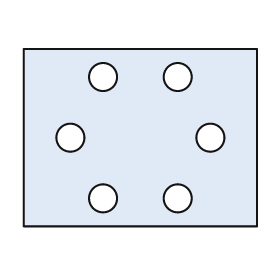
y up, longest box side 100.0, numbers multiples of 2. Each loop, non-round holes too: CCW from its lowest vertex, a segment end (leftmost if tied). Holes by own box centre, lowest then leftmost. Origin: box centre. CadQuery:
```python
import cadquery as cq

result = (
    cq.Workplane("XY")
    .moveTo(-50.0, -38.0)
    .lineTo(50.0, -38.0)
    .lineTo(50.0, 38.0)
    .lineTo(-50.0, 38.0)
    .close()
    .moveTo(-16.0, -26.0)
    .circle(6.0)
    .moveTo(16.0, -26.0)
    .circle(6.0)
    .moveTo(-30.0, 0.0)
    .circle(6.0)
    .moveTo(30.0, 0.0)
    .circle(6.0)
    .moveTo(-16.0, 26.0)
    .circle(6.0)
    .moveTo(16.0, 26.0)
    .circle(6.0)
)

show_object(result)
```